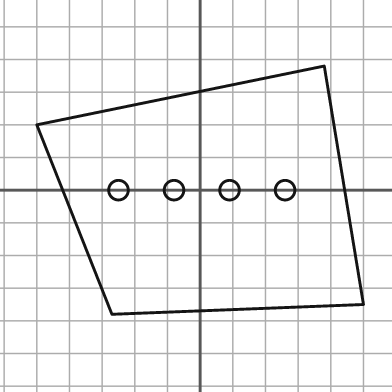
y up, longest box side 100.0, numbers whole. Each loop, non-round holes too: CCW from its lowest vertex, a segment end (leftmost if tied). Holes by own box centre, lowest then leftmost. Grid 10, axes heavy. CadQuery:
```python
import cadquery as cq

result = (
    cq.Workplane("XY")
    .moveTo(-27.0, -38.0)
    .lineTo(50.0, -35.0)
    .lineTo(38.0, 38.0)
    .lineTo(-50.0, 20.0)
    .close()
    .moveTo(-25.0, 0.0)
    .circle(3.0)
    .moveTo(-8.0, 0.0)
    .circle(3.0)
    .moveTo(9.0, 0.0)
    .circle(3.0)
    .moveTo(26.0, 0.0)
    .circle(3.0)
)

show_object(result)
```